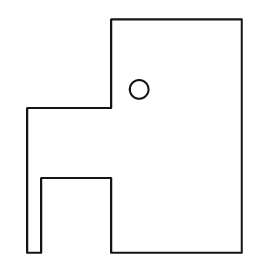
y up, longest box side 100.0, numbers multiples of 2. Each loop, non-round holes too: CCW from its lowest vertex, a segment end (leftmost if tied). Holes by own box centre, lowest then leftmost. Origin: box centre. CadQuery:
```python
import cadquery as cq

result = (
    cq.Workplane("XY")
    .moveTo(-46.0, -50.0)
    .lineTo(-40.0, -50.0)
    .lineTo(-40.0, -18.0)
    .lineTo(-10.0, -18.0)
    .lineTo(-10.0, -50.0)
    .lineTo(46.0, -50.0)
    .lineTo(46.0, 50.0)
    .lineTo(-10.0, 50.0)
    .lineTo(-10.0, 12.0)
    .lineTo(-46.0, 12.0)
    .close()
    .moveTo(2.0, 20.0)
    .circle(4.0)
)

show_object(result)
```